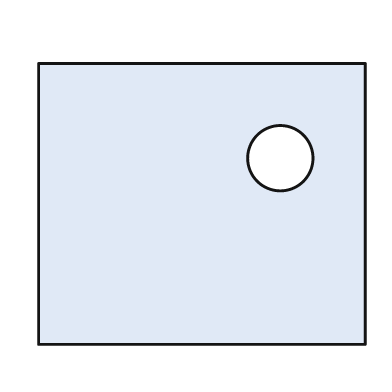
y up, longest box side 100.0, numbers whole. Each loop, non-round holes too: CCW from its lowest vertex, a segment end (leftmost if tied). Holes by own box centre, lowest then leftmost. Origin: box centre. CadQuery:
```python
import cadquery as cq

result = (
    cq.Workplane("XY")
    .moveTo(-50.0, -43.0)
    .lineTo(50.0, -43.0)
    .lineTo(50.0, 43.0)
    .lineTo(-50.0, 43.0)
    .close()
    .moveTo(24.0, 14.0)
    .circle(10.0)
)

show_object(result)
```